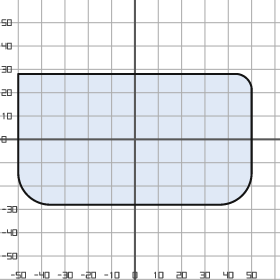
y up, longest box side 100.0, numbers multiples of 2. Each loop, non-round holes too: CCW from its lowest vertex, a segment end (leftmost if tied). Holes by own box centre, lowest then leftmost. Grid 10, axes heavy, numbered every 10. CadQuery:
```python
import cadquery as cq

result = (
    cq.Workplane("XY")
    .moveTo(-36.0, -28.0)
    .lineTo(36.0, -28.0)
    .threePointArc((46.0, -24.0), (50.0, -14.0))
    .lineTo(50.0, 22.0)
    .threePointArc((48.0, 26.0), (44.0, 28.0))
    .lineTo(-50.0, 28.0)
    .lineTo(-50.0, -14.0)
    .threePointArc((-46.0, -24.0), (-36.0, -28.0))
    .close()
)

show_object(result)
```